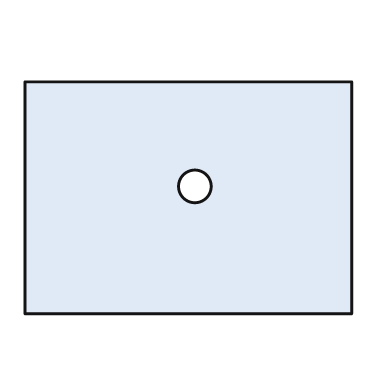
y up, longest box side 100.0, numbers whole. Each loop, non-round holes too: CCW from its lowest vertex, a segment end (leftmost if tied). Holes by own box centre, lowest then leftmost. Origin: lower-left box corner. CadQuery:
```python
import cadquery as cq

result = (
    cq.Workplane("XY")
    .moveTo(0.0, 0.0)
    .lineTo(100.0, 0.0)
    .lineTo(100.0, 71.0)
    .lineTo(0.0, 71.0)
    .close()
    .moveTo(52.0, 39.0)
    .circle(5.0)
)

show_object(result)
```